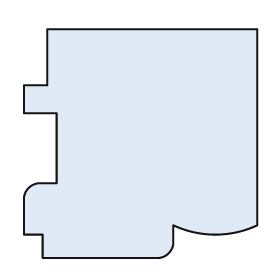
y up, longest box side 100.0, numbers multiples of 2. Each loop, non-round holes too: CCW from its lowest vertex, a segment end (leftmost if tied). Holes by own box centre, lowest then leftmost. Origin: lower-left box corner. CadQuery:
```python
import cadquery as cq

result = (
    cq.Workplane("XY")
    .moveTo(8.0, 0.0)
    .lineTo(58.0, 0.0)
    .threePointArc((62.0, 2.0), (64.0, 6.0))
    .lineTo(64.0, 14.0)
    .threePointArc((82.0, 10.0), (100.0, 14.0))
    .lineTo(100.0, 98.0)
    .lineTo(10.0, 98.0)
    .lineTo(10.0, 74.0)
    .lineTo(0.0, 74.0)
    .lineTo(0.0, 62.0)
    .lineTo(14.0, 62.0)
    .lineTo(14.0, 32.0)
    .lineTo(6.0, 32.0)
    .threePointArc((2.0, 30.0), (0.0, 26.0))
    .lineTo(0.0, 10.0)
    .lineTo(8.0, 10.0)
    .close()
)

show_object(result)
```